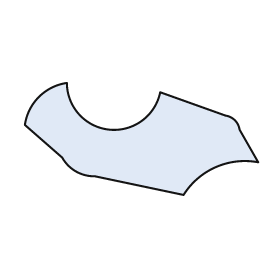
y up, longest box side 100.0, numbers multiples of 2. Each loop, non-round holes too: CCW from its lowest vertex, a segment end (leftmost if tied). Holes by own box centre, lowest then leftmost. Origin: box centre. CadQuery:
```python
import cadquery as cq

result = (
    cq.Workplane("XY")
    .moveTo(18.0, -24.0)
    .threePointArc((32.0, -12.0), (50.0, -10.0))
    .lineTo(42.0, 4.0)
    .threePointArc((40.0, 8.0), (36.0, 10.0))
    .lineTo(8.0, 20.0)
    .threePointArc((-14.0, 4.0), (-32.0, 24.0))
    .threePointArc((-44.0, 18.0), (-50.0, 6.0))
    .lineTo(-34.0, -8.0)
    .threePointArc((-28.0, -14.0), (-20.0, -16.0))
    .close()
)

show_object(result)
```